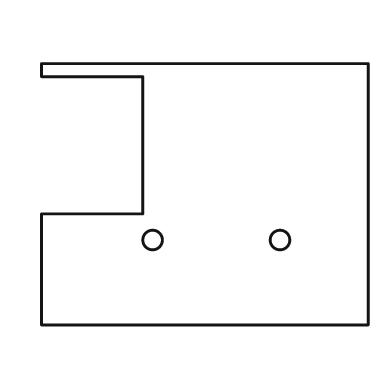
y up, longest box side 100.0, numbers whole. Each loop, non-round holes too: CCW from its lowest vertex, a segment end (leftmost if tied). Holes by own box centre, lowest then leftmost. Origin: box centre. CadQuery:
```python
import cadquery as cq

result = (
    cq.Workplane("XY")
    .moveTo(-50.0, -40.0)
    .lineTo(50.0, -40.0)
    .lineTo(50.0, 40.0)
    .lineTo(-50.0, 40.0)
    .lineTo(-50.0, 36.0)
    .lineTo(-19.0, 36.0)
    .lineTo(-19.0, -6.0)
    .lineTo(-50.0, -6.0)
    .close()
    .moveTo(-16.0, -14.0)
    .circle(3.0)
    .moveTo(23.0, -14.0)
    .circle(3.0)
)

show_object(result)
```